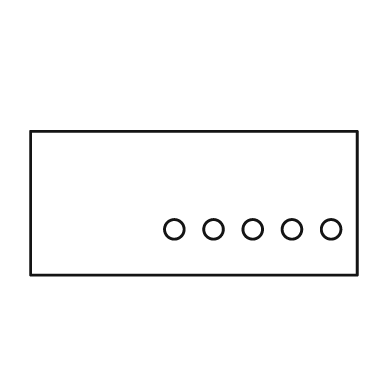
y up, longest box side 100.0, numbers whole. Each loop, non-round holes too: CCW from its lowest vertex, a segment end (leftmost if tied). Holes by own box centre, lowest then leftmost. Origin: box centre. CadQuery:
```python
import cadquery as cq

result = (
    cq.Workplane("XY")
    .moveTo(-50.0, -22.0)
    .lineTo(50.0, -22.0)
    .lineTo(50.0, 22.0)
    .lineTo(-50.0, 22.0)
    .close()
    .moveTo(-6.0, -8.0)
    .circle(3.0)
    .moveTo(6.0, -8.0)
    .circle(3.0)
    .moveTo(18.0, -8.0)
    .circle(3.0)
    .moveTo(30.0, -8.0)
    .circle(3.0)
    .moveTo(42.0, -8.0)
    .circle(3.0)
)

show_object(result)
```